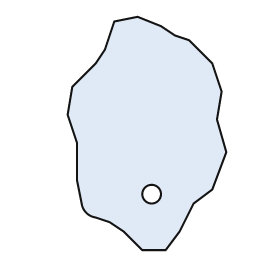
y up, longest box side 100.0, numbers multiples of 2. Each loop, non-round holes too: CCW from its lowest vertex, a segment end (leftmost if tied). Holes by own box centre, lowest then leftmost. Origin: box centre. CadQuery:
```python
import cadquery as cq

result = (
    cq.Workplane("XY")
    .moveTo(-2.0, -50.0)
    .lineTo(8.0, -50.0)
    .lineTo(14.0, -42.0)
    .lineTo(20.0, -30.0)
    .lineTo(28.0, -24.0)
    .lineTo(34.0, -8.0)
    .lineTo(30.0, 6.0)
    .lineTo(32.0, 18.0)
    .lineTo(28.0, 30.0)
    .lineTo(18.0, 40.0)
    .lineTo(12.0, 42.0)
    .lineTo(6.0, 46.0)
    .lineTo(-4.0, 50.0)
    .lineTo(-14.0, 48.0)
    .lineTo(-18.0, 36.0)
    .lineTo(-22.0, 30.0)
    .lineTo(-32.0, 20.0)
    .lineTo(-34.0, 8.0)
    .lineTo(-30.0, -4.0)
    .lineTo(-30.0, -20.0)
    .lineTo(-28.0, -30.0)
    .threePointArc((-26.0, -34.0), (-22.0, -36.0))
    .lineTo(-16.0, -38.0)
    .lineTo(-10.0, -42.0)
    .close()
    .moveTo(2.0, -26.0)
    .circle(4.0)
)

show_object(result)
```